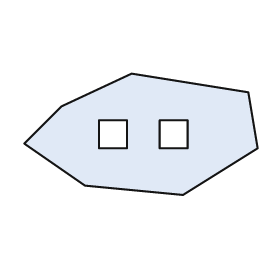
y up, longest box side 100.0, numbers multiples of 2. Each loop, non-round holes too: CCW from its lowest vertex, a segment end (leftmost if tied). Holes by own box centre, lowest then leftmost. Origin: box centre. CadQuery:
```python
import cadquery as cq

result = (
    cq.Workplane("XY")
    .moveTo(18.0, -26.0)
    .lineTo(50.0, -6.0)
    .lineTo(46.0, 18.0)
    .lineTo(-4.0, 26.0)
    .lineTo(-34.0, 12.0)
    .lineTo(-50.0, -4.0)
    .lineTo(-24.0, -22.0)
    .close()
    .moveTo(-18.0, -6.0)
    .lineTo(-6.0, -6.0)
    .lineTo(-6.0, 6.0)
    .lineTo(-18.0, 6.0)
    .close()
    .moveTo(8.0, -6.0)
    .lineTo(20.0, -6.0)
    .lineTo(20.0, 6.0)
    .lineTo(8.0, 6.0)
    .close()
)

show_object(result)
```